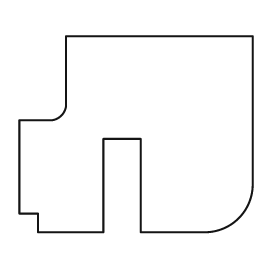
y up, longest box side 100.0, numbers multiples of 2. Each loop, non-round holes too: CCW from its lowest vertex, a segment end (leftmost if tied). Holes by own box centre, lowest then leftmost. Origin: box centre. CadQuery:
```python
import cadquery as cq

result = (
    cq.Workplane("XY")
    .moveTo(-42.0, -42.0)
    .lineTo(-14.0, -42.0)
    .lineTo(-14.0, -2.0)
    .lineTo(2.0, -2.0)
    .lineTo(2.0, -42.0)
    .lineTo(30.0, -42.0)
    .threePointArc((44.0, -36.0), (50.0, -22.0))
    .lineTo(50.0, 42.0)
    .lineTo(-30.0, 42.0)
    .lineTo(-30.0, 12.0)
    .threePointArc((-32.0, 8.0), (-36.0, 6.0))
    .lineTo(-50.0, 6.0)
    .lineTo(-50.0, -34.0)
    .lineTo(-42.0, -34.0)
    .close()
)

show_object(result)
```